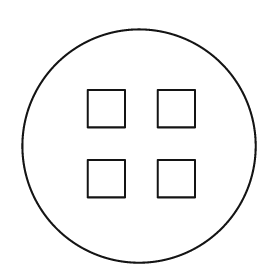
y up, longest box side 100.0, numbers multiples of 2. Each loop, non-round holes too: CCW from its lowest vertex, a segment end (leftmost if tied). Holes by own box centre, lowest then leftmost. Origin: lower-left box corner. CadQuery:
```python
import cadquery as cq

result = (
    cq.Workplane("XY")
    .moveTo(50.0, 50.0)
    .circle(50.0)
    .moveTo(28.0, 28.0)
    .lineTo(44.0, 28.0)
    .lineTo(44.0, 44.0)
    .lineTo(28.0, 44.0)
    .close()
    .moveTo(58.0, 28.0)
    .lineTo(74.0, 28.0)
    .lineTo(74.0, 44.0)
    .lineTo(58.0, 44.0)
    .close()
    .moveTo(28.0, 58.0)
    .lineTo(44.0, 58.0)
    .lineTo(44.0, 74.0)
    .lineTo(28.0, 74.0)
    .close()
    .moveTo(58.0, 58.0)
    .lineTo(74.0, 58.0)
    .lineTo(74.0, 74.0)
    .lineTo(58.0, 74.0)
    .close()
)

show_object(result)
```